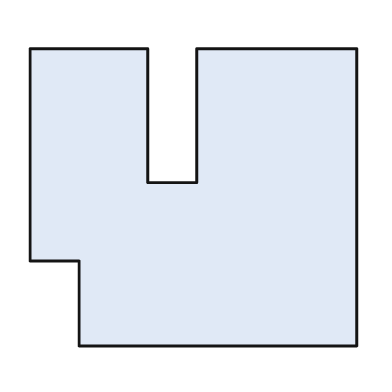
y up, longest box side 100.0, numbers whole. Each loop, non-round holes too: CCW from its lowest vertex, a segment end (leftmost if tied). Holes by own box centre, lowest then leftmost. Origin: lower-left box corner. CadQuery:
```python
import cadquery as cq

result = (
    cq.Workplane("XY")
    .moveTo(15.0, 0.0)
    .lineTo(100.0, 0.0)
    .lineTo(100.0, 91.0)
    .lineTo(51.0, 91.0)
    .lineTo(51.0, 50.0)
    .lineTo(36.0, 50.0)
    .lineTo(36.0, 91.0)
    .lineTo(0.0, 91.0)
    .lineTo(0.0, 26.0)
    .lineTo(15.0, 26.0)
    .close()
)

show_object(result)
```